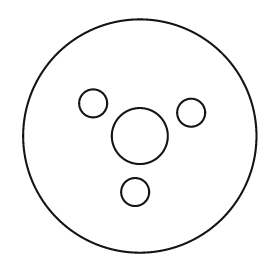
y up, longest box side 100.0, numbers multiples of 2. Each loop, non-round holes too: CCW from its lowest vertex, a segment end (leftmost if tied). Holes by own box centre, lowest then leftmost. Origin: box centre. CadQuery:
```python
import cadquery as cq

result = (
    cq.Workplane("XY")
    .moveTo(0.0, 0.0)
    .circle(50.0)
    .moveTo(-2.0, -24.0)
    .circle(6.0)
    .moveTo(0.0, 0.0)
    .circle(12.0)
    .moveTo(22.0, 10.0)
    .circle(6.0)
    .moveTo(-20.0, 14.0)
    .circle(6.0)
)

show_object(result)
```